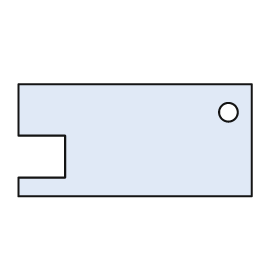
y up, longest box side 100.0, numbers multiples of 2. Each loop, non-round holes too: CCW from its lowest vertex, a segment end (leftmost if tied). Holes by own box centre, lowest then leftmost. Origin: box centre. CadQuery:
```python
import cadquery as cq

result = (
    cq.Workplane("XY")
    .moveTo(-50.0, -24.0)
    .lineTo(50.0, -24.0)
    .lineTo(50.0, 24.0)
    .lineTo(-50.0, 24.0)
    .lineTo(-50.0, 2.0)
    .lineTo(-30.0, 2.0)
    .lineTo(-30.0, -16.0)
    .lineTo(-50.0, -16.0)
    .close()
    .moveTo(40.0, 12.0)
    .circle(4.0)
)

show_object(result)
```